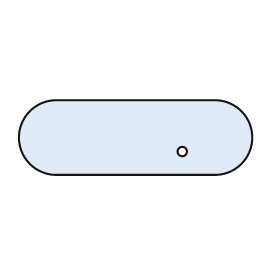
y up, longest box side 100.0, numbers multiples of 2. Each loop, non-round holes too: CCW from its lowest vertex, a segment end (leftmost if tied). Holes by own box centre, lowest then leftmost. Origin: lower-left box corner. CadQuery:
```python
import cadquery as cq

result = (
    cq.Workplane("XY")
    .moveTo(16.0, 0.0)
    .lineTo(84.0, 0.0)
    .threePointArc((100.0, 16.0), (84.0, 32.0))
    .lineTo(16.0, 32.0)
    .threePointArc((0.0, 16.0), (16.0, 0.0))
    .close()
    .moveTo(70.0, 10.0)
    .circle(2.0)
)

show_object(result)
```